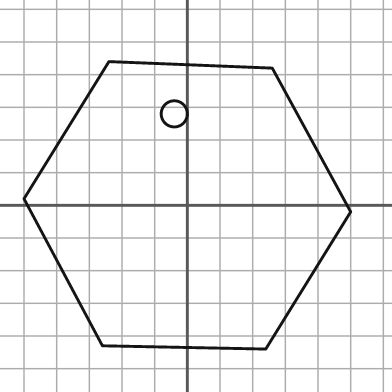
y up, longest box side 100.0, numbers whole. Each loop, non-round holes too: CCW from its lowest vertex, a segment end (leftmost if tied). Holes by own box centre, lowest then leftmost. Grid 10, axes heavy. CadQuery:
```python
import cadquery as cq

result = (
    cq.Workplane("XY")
    .moveTo(24.0, -44.0)
    .lineTo(50.0, -2.0)
    .lineTo(26.0, 42.0)
    .lineTo(-24.0, 44.0)
    .lineTo(-50.0, 2.0)
    .lineTo(-26.0, -43.0)
    .close()
    .moveTo(-4.0, 28.0)
    .circle(4.0)
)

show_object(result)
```